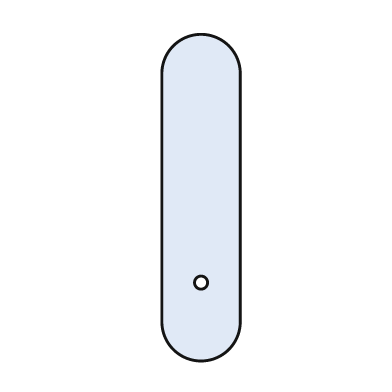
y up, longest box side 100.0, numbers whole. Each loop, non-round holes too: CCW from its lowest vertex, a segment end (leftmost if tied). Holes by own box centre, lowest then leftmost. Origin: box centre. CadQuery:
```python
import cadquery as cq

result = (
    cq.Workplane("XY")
    .moveTo(-12.0, -38.0)
    .threePointArc((0.0, -50.0), (12.0, -38.0))
    .lineTo(12.0, 38.0)
    .threePointArc((0.0, 50.0), (-12.0, 38.0))
    .close()
    .moveTo(0.0, -26.0)
    .circle(2.0)
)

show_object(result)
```